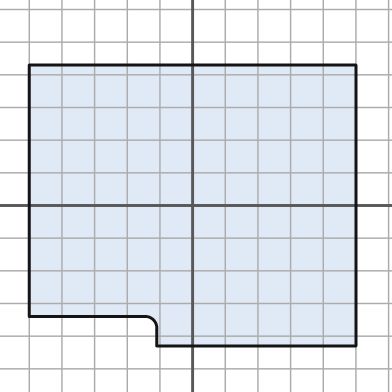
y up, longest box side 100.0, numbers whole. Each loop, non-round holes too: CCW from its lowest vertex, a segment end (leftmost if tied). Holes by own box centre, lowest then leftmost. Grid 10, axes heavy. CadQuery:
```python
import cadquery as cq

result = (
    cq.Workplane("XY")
    .moveTo(-11.0, -43.0)
    .lineTo(50.0, -43.0)
    .lineTo(50.0, 43.0)
    .lineTo(-50.0, 43.0)
    .lineTo(-50.0, -34.0)
    .lineTo(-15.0, -34.0)
    .threePointArc((-12.0, -35.0), (-11.0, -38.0))
    .close()
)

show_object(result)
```